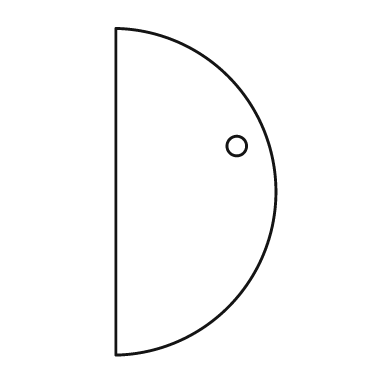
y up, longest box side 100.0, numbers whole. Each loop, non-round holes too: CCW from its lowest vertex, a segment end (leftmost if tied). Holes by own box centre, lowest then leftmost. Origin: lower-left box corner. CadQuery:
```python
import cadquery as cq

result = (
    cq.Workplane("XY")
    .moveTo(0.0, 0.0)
    .threePointArc((49.0, 50.0), (0.0, 100.0))
    .close()
    .moveTo(37.0, 64.0)
    .circle(3.0)
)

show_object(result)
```